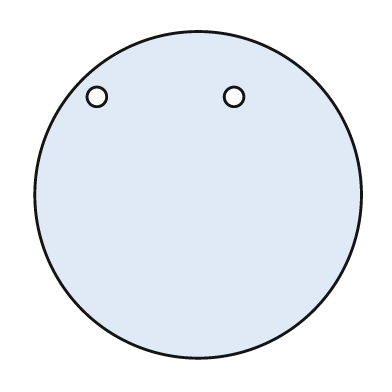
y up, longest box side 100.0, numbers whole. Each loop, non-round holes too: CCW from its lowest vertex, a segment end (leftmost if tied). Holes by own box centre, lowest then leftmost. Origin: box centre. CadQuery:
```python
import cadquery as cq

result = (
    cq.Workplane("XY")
    .moveTo(0.0, 0.0)
    .circle(50.0)
    .moveTo(-31.0, 30.0)
    .circle(3.0)
    .moveTo(11.0, 30.0)
    .circle(3.0)
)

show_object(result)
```